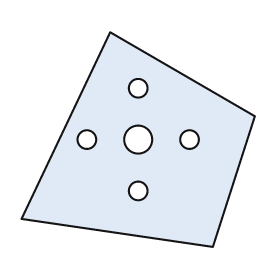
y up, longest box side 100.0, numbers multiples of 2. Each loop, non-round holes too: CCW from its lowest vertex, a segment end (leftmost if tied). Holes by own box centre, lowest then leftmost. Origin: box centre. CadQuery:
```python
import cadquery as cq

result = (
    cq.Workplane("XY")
    .moveTo(32.0, -46.0)
    .lineTo(50.0, 10.0)
    .lineTo(-12.0, 46.0)
    .lineTo(-50.0, -34.0)
    .close()
    .moveTo(0.0, -22.0)
    .circle(4.0)
    .moveTo(-22.0, 0.0)
    .circle(4.0)
    .moveTo(0.0, 0.0)
    .circle(6.0)
    .moveTo(22.0, 0.0)
    .circle(4.0)
    .moveTo(0.0, 22.0)
    .circle(4.0)
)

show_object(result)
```